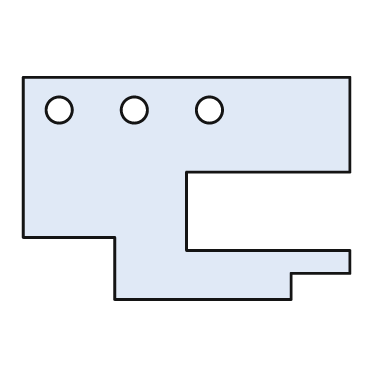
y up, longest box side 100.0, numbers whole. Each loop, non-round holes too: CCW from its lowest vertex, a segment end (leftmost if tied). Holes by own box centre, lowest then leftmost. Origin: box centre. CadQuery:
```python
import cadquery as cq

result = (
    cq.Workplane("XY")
    .moveTo(-22.0, -34.0)
    .lineTo(32.0, -34.0)
    .lineTo(32.0, -26.0)
    .lineTo(50.0, -26.0)
    .lineTo(50.0, -19.0)
    .lineTo(0.0, -19.0)
    .lineTo(0.0, 5.0)
    .lineTo(50.0, 5.0)
    .lineTo(50.0, 34.0)
    .lineTo(-50.0, 34.0)
    .lineTo(-50.0, -15.0)
    .lineTo(-22.0, -15.0)
    .close()
    .moveTo(-39.0, 24.0)
    .circle(4.0)
    .moveTo(-16.0, 24.0)
    .circle(4.0)
    .moveTo(7.0, 24.0)
    .circle(4.0)
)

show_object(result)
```